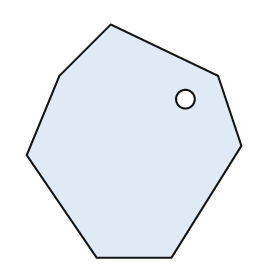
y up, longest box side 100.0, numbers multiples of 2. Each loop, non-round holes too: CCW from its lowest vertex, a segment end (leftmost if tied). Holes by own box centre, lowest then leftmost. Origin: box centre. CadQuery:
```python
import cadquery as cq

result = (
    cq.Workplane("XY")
    .moveTo(-16.0, -50.0)
    .lineTo(16.0, -50.0)
    .lineTo(46.0, -2.0)
    .lineTo(36.0, 28.0)
    .lineTo(-10.0, 50.0)
    .lineTo(-32.0, 28.0)
    .lineTo(-46.0, -6.0)
    .close()
    .moveTo(22.0, 18.0)
    .circle(4.0)
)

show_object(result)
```